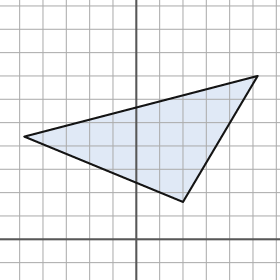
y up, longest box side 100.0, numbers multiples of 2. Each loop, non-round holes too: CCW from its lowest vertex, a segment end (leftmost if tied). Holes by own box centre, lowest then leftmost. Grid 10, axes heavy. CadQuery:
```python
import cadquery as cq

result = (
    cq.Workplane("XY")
    .moveTo(20.0, 16.0)
    .lineTo(52.0, 70.0)
    .lineTo(-48.0, 44.0)
    .close()
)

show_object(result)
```